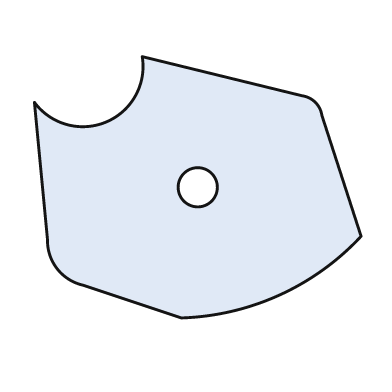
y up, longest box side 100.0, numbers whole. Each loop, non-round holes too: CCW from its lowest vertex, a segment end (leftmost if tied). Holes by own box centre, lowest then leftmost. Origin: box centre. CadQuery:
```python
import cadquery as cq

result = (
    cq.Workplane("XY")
    .moveTo(-5.0, -40.0)
    .threePointArc((25.0, -33.0), (50.0, -15.0))
    .lineTo(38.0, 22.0)
    .threePointArc((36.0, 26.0), (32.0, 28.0))
    .lineTo(-17.0, 40.0)
    .threePointArc((-28.0, 20.0), (-50.0, 26.0))
    .lineTo(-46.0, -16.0)
    .threePointArc((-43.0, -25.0), (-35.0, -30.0))
    .close()
    .moveTo(0.0, 0.0)
    .circle(6.0)
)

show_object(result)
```